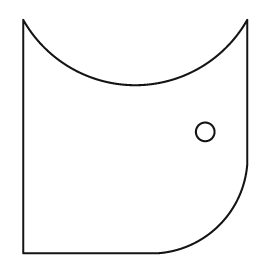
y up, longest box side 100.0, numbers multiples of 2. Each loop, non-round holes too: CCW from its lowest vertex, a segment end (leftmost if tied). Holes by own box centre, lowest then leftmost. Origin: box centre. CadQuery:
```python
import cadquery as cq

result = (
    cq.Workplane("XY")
    .moveTo(-48.0, -50.0)
    .lineTo(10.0, -50.0)
    .threePointArc((36.0, -38.0), (48.0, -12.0))
    .lineTo(48.0, 50.0)
    .threePointArc((0.0, 22.0), (-48.0, 50.0))
    .close()
    .moveTo(30.0, 2.0)
    .circle(4.0)
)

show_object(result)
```